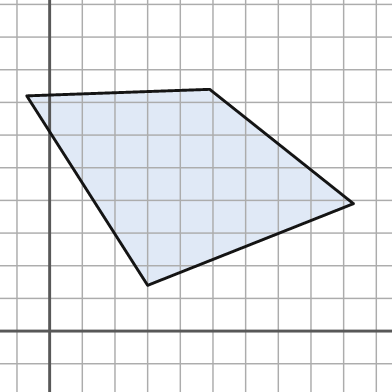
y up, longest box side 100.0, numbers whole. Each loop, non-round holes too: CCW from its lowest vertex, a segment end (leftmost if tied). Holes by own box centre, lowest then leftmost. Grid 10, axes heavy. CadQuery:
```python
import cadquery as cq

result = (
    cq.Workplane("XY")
    .moveTo(30.0, 14.0)
    .lineTo(93.0, 39.0)
    .lineTo(49.0, 74.0)
    .lineTo(-7.0, 72.0)
    .close()
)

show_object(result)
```